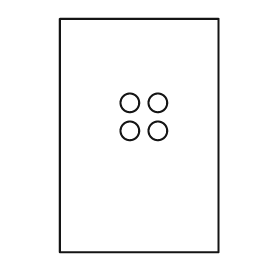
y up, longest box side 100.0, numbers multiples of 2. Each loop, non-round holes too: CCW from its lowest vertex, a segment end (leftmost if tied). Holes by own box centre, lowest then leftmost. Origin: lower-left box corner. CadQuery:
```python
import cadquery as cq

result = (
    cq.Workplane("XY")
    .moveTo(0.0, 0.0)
    .lineTo(68.0, 0.0)
    .lineTo(68.0, 100.0)
    .lineTo(0.0, 100.0)
    .close()
    .moveTo(30.0, 52.0)
    .circle(4.0)
    .moveTo(42.0, 52.0)
    .circle(4.0)
    .moveTo(30.0, 64.0)
    .circle(4.0)
    .moveTo(42.0, 64.0)
    .circle(4.0)
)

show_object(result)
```